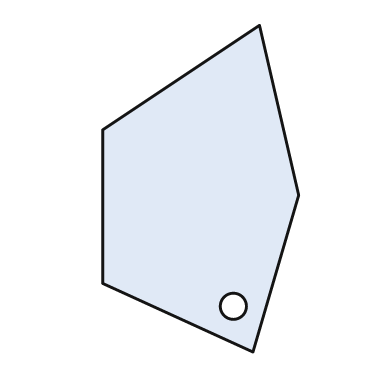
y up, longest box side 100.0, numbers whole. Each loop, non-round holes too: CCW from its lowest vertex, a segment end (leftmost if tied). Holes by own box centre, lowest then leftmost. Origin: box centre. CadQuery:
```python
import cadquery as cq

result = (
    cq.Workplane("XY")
    .moveTo(16.0, -50.0)
    .lineTo(30.0, -2.0)
    .lineTo(18.0, 50.0)
    .lineTo(-30.0, 18.0)
    .lineTo(-30.0, -29.0)
    .close()
    .moveTo(10.0, -36.0)
    .circle(4.0)
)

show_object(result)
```